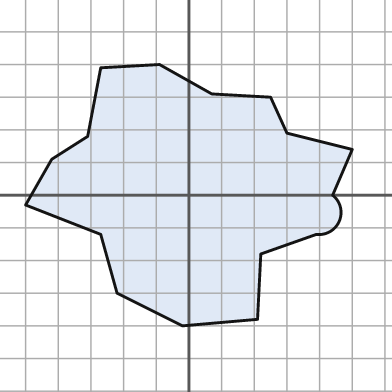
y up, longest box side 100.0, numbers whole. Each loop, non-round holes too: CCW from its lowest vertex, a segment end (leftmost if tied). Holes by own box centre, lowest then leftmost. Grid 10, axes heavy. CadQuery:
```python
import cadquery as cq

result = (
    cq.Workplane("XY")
    .moveTo(-2.0, -40.0)
    .lineTo(21.0, -38.0)
    .lineTo(22.0, -18.0)
    .lineTo(39.0, -12.0)
    .threePointArc((46.0, -8.0), (44.0, 0.0))
    .lineTo(50.0, 14.0)
    .lineTo(30.0, 19.0)
    .lineTo(25.0, 30.0)
    .lineTo(7.0, 31.0)
    .lineTo(-9.0, 40.0)
    .lineTo(-27.0, 39.0)
    .lineTo(-31.0, 18.0)
    .lineTo(-42.0, 11.0)
    .lineTo(-50.0, -3.0)
    .lineTo(-27.0, -12.0)
    .lineTo(-22.0, -30.0)
    .close()
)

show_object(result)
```